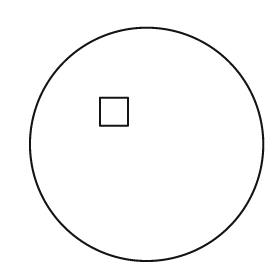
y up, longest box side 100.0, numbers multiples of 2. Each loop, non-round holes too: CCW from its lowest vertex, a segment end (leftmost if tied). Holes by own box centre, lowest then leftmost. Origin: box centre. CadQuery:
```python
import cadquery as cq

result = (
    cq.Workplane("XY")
    .moveTo(0.0, 0.0)
    .circle(50.0)
    .moveTo(-20.0, 8.0)
    .lineTo(-8.0, 8.0)
    .lineTo(-8.0, 20.0)
    .lineTo(-20.0, 20.0)
    .close()
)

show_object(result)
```